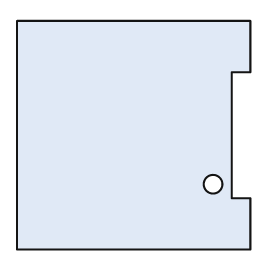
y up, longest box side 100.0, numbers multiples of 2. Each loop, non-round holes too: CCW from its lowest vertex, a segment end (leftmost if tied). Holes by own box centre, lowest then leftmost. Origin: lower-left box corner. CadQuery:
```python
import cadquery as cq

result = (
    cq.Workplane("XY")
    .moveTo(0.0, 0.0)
    .lineTo(100.0, 0.0)
    .lineTo(100.0, 22.0)
    .lineTo(92.0, 22.0)
    .lineTo(92.0, 76.0)
    .lineTo(100.0, 76.0)
    .lineTo(100.0, 98.0)
    .lineTo(0.0, 98.0)
    .close()
    .moveTo(84.0, 28.0)
    .circle(4.0)
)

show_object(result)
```